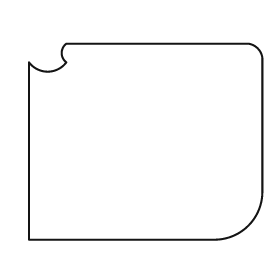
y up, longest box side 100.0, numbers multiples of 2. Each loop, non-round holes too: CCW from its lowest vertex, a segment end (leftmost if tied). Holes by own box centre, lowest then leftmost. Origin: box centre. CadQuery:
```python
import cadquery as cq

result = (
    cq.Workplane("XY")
    .moveTo(-50.0, -42.0)
    .lineTo(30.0, -42.0)
    .threePointArc((44.0, -36.0), (50.0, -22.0))
    .lineTo(50.0, 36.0)
    .threePointArc((48.0, 40.0), (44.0, 42.0))
    .lineTo(-34.0, 42.0)
    .threePointArc((-36.0, 38.0), (-34.0, 34.0))
    .threePointArc((-42.0, 30.0), (-50.0, 34.0))
    .close()
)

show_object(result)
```